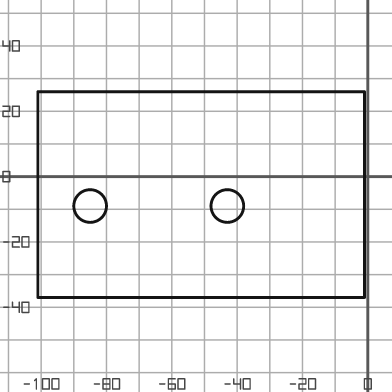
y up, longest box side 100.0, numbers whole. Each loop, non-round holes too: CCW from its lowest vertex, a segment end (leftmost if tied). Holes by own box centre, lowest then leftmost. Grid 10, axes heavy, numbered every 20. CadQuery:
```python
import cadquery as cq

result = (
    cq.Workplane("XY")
    .moveTo(-101.0, -37.0)
    .lineTo(-1.0, -37.0)
    .lineTo(-1.0, 26.0)
    .lineTo(-101.0, 26.0)
    .close()
    .moveTo(-85.0, -9.0)
    .circle(5.0)
    .moveTo(-43.0, -9.0)
    .circle(5.0)
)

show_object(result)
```